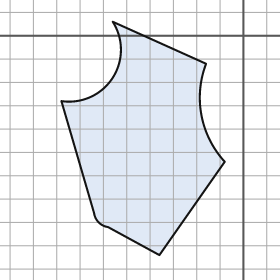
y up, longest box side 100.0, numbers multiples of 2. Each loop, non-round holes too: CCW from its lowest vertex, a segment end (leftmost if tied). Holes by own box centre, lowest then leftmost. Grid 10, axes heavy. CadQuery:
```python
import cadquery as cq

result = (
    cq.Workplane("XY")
    .moveTo(-36.0, -94.0)
    .lineTo(-8.0, -54.0)
    .threePointArc((-18.0, -34.0), (-16.0, -12.0))
    .lineTo(-56.0, 6.0)
    .threePointArc((-56.0, -18.0), (-78.0, -28.0))
    .lineTo(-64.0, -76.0)
    .threePointArc((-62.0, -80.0), (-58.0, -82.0))
    .close()
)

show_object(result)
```